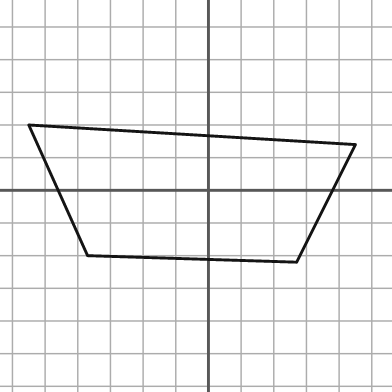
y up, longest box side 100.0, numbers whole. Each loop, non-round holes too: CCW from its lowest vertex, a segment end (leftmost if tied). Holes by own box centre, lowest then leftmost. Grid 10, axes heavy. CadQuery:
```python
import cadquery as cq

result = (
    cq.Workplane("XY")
    .moveTo(27.0, -22.0)
    .lineTo(45.0, 14.0)
    .lineTo(-55.0, 20.0)
    .lineTo(-37.0, -20.0)
    .close()
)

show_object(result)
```